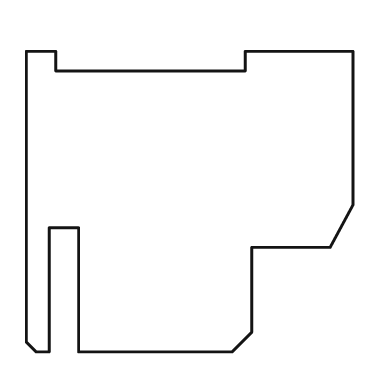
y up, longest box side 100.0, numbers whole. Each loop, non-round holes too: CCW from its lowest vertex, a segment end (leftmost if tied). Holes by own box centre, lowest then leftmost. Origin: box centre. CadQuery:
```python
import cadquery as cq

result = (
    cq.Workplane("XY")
    .moveTo(-47.0, -46.0)
    .lineTo(-43.0, -46.0)
    .lineTo(-43.0, -8.0)
    .lineTo(-34.0, -8.0)
    .lineTo(-34.0, -46.0)
    .lineTo(13.0, -46.0)
    .lineTo(19.0, -40.0)
    .lineTo(19.0, -14.0)
    .lineTo(43.0, -14.0)
    .lineTo(50.0, -1.0)
    .lineTo(50.0, 46.0)
    .lineTo(17.0, 46.0)
    .lineTo(17.0, 40.0)
    .lineTo(-41.0, 40.0)
    .lineTo(-41.0, 46.0)
    .lineTo(-50.0, 46.0)
    .lineTo(-50.0, -43.0)
    .close()
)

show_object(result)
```